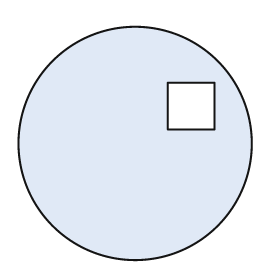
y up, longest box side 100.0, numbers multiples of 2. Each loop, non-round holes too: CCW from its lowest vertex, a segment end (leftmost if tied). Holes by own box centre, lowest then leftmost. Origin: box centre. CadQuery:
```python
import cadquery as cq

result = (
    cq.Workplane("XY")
    .moveTo(0.0, 0.0)
    .circle(50.0)
    .moveTo(14.0, 6.0)
    .lineTo(34.0, 6.0)
    .lineTo(34.0, 26.0)
    .lineTo(14.0, 26.0)
    .close()
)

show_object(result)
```